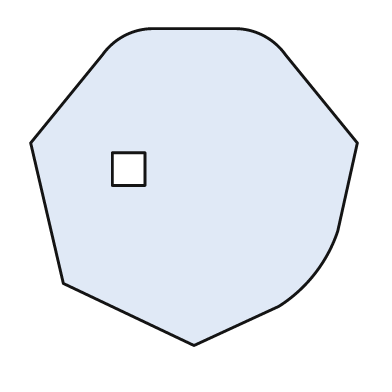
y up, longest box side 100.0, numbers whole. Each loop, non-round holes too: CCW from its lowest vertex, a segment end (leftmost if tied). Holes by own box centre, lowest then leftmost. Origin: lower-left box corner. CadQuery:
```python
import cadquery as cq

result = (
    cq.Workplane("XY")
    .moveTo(50.0, 0.0)
    .lineTo(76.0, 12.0)
    .threePointArc((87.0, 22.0), (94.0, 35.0))
    .lineTo(100.0, 62.0)
    .lineTo(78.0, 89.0)
    .threePointArc((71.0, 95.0), (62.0, 97.0))
    .lineTo(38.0, 97.0)
    .threePointArc((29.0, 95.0), (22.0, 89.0))
    .lineTo(0.0, 62.0)
    .lineTo(10.0, 19.0)
    .close()
    .moveTo(25.0, 49.0)
    .lineTo(35.0, 49.0)
    .lineTo(35.0, 59.0)
    .lineTo(25.0, 59.0)
    .close()
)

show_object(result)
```